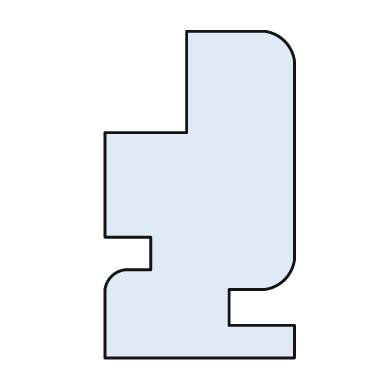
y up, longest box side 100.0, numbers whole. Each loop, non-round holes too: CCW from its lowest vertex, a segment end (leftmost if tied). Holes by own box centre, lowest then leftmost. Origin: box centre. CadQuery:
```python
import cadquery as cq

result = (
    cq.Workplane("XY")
    .moveTo(-29.0, -50.0)
    .lineTo(29.0, -50.0)
    .lineTo(29.0, -40.0)
    .lineTo(9.0, -40.0)
    .lineTo(9.0, -29.0)
    .lineTo(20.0, -29.0)
    .threePointArc((26.0, -26.0), (29.0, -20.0))
    .lineTo(29.0, 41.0)
    .threePointArc((26.0, 47.0), (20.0, 50.0))
    .lineTo(-4.0, 50.0)
    .lineTo(-4.0, 19.0)
    .lineTo(-29.0, 19.0)
    .lineTo(-29.0, -13.0)
    .lineTo(-15.0, -13.0)
    .lineTo(-15.0, -23.0)
    .lineTo(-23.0, -23.0)
    .threePointArc((-27.0, -25.0), (-29.0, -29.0))
    .close()
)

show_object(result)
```